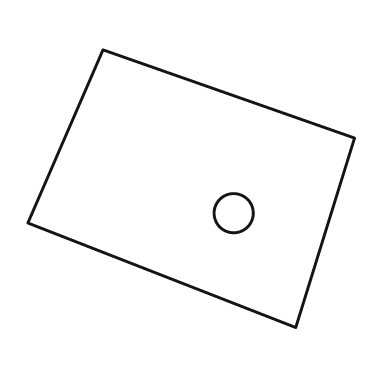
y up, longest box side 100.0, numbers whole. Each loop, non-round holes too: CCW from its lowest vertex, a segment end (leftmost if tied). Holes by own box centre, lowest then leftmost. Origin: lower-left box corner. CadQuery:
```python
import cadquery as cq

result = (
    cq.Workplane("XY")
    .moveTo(82.0, 0.0)
    .lineTo(100.0, 58.0)
    .lineTo(23.0, 85.0)
    .lineTo(0.0, 32.0)
    .close()
    .moveTo(63.0, 35.0)
    .circle(6.0)
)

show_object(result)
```